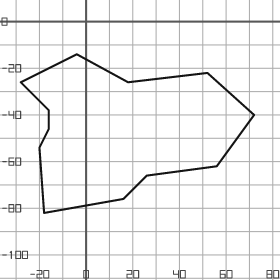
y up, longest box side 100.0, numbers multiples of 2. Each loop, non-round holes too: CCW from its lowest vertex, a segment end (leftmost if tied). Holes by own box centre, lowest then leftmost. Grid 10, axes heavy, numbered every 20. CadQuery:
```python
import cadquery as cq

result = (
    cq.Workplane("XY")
    .moveTo(-18.0, -82.0)
    .lineTo(16.0, -76.0)
    .lineTo(26.0, -66.0)
    .lineTo(56.0, -62.0)
    .lineTo(72.0, -40.0)
    .lineTo(52.0, -22.0)
    .lineTo(18.0, -26.0)
    .lineTo(-4.0, -14.0)
    .lineTo(-28.0, -26.0)
    .lineTo(-16.0, -38.0)
    .lineTo(-16.0, -46.0)
    .lineTo(-20.0, -54.0)
    .close()
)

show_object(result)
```